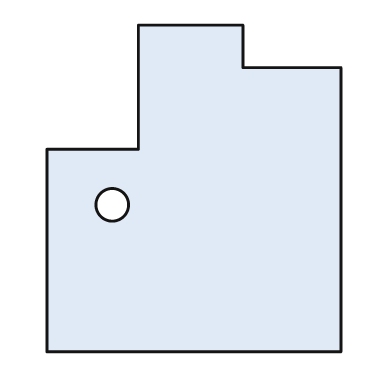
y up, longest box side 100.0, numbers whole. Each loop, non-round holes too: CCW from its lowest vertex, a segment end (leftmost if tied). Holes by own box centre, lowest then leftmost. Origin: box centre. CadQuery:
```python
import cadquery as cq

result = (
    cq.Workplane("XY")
    .moveTo(-45.0, -50.0)
    .lineTo(45.0, -50.0)
    .lineTo(45.0, 37.0)
    .lineTo(15.0, 37.0)
    .lineTo(15.0, 50.0)
    .lineTo(-17.0, 50.0)
    .lineTo(-17.0, 12.0)
    .lineTo(-45.0, 12.0)
    .close()
    .moveTo(-25.0, -5.0)
    .circle(5.0)
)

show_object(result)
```